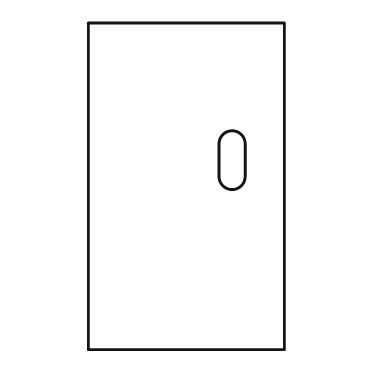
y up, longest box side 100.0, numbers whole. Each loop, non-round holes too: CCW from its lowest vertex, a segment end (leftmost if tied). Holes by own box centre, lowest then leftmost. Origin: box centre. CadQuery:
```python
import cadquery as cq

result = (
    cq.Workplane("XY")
    .moveTo(-30.0, -50.0)
    .lineTo(30.0, -50.0)
    .lineTo(30.0, 50.0)
    .lineTo(-30.0, 50.0)
    .close()
    .moveTo(10.0, 3.0)
    .threePointArc((14.0, -1.0), (18.0, 3.0))
    .lineTo(18.0, 13.0)
    .threePointArc((14.0, 17.0), (10.0, 13.0))
    .close()
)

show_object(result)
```